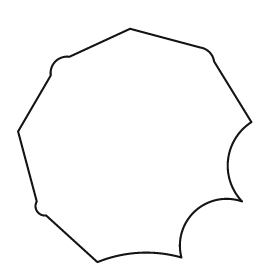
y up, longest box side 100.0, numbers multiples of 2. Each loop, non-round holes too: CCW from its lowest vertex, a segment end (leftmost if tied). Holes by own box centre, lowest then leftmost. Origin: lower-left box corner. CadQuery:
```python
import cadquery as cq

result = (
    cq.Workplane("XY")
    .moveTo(34.0, 0.0)
    .threePointArc((52.0, 4.0), (70.0, 2.0))
    .threePointArc((76.0, 22.0), (96.0, 26.0))
    .threePointArc((90.0, 44.0), (100.0, 60.0))
    .lineTo(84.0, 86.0)
    .threePointArc((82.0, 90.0), (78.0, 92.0))
    .lineTo(48.0, 100.0)
    .lineTo(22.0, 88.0)
    .threePointArc((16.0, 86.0), (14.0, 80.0))
    .lineTo(0.0, 56.0)
    .lineTo(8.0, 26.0)
    .threePointArc((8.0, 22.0), (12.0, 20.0))
    .close()
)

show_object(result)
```